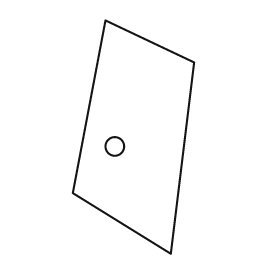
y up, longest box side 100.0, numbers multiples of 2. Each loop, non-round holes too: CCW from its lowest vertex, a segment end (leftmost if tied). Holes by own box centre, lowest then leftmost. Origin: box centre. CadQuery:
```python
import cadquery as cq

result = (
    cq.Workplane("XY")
    .moveTo(16.0, -50.0)
    .lineTo(26.0, 32.0)
    .lineTo(-12.0, 50.0)
    .lineTo(-26.0, -24.0)
    .close()
    .moveTo(-8.0, -4.0)
    .circle(4.0)
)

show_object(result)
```